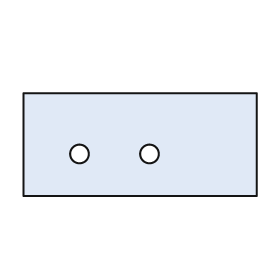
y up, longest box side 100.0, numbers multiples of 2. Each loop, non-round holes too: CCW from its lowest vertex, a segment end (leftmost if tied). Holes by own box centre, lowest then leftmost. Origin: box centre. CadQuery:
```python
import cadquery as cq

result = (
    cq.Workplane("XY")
    .moveTo(-50.0, -22.0)
    .lineTo(50.0, -22.0)
    .lineTo(50.0, 22.0)
    .lineTo(-50.0, 22.0)
    .close()
    .moveTo(-26.0, -4.0)
    .circle(4.0)
    .moveTo(4.0, -4.0)
    .circle(4.0)
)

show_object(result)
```